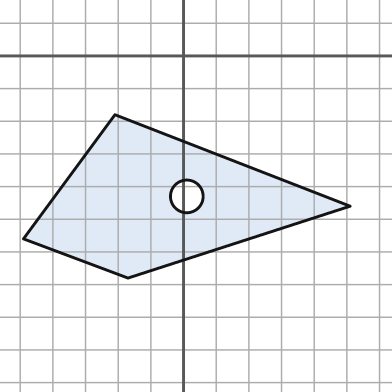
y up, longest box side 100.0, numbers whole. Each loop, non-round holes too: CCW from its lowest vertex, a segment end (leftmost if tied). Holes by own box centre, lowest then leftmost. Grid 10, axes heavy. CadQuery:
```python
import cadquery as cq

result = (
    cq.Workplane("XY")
    .moveTo(-17.0, -68.0)
    .lineTo(51.0, -46.0)
    .lineTo(-21.0, -18.0)
    .lineTo(-49.0, -56.0)
    .close()
    .moveTo(1.0, -43.0)
    .circle(5.0)
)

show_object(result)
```